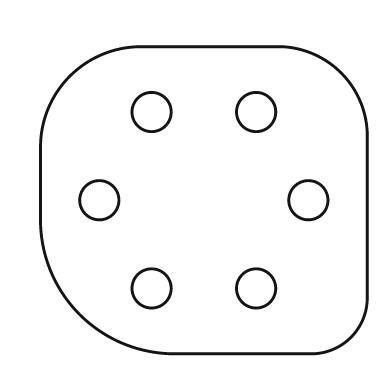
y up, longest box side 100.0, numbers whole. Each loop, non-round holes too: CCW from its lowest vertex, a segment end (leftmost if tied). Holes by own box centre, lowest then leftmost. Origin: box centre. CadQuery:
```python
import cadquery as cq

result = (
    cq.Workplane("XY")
    .moveTo(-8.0, -47.0)
    .lineTo(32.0, -47.0)
    .threePointArc((45.0, -42.0), (50.0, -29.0))
    .lineTo(50.0, 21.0)
    .threePointArc((42.0, 39.0), (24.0, 47.0))
    .lineTo(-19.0, 47.0)
    .threePointArc((-41.0, 38.0), (-50.0, 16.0))
    .lineTo(-50.0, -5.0)
    .threePointArc((-38.0, -35.0), (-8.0, -47.0))
    .close()
    .moveTo(-16.0, -27.0)
    .circle(6.0)
    .moveTo(16.0, -27.0)
    .circle(6.0)
    .moveTo(-32.0, 0.0)
    .circle(6.0)
    .moveTo(32.0, 0.0)
    .circle(6.0)
    .moveTo(-16.0, 27.0)
    .circle(6.0)
    .moveTo(16.0, 27.0)
    .circle(6.0)
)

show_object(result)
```